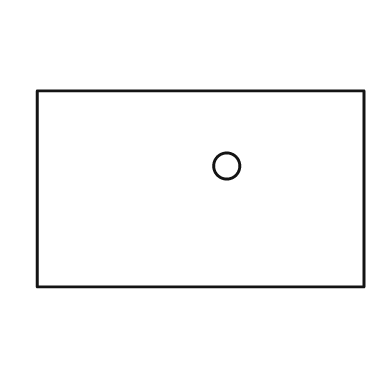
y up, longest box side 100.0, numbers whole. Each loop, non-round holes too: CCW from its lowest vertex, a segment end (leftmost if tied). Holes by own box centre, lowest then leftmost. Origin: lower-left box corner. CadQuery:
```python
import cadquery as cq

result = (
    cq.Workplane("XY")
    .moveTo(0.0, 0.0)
    .lineTo(100.0, 0.0)
    .lineTo(100.0, 60.0)
    .lineTo(0.0, 60.0)
    .close()
    .moveTo(58.0, 37.0)
    .circle(4.0)
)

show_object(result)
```